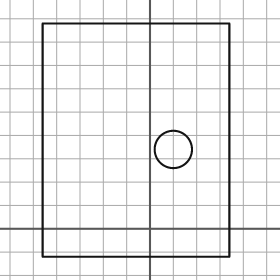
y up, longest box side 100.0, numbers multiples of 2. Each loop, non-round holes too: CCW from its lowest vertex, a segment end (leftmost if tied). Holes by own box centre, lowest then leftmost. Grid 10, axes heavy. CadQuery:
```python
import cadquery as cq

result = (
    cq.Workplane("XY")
    .moveTo(-46.0, -12.0)
    .lineTo(34.0, -12.0)
    .lineTo(34.0, 88.0)
    .lineTo(-46.0, 88.0)
    .close()
    .moveTo(10.0, 34.0)
    .circle(8.0)
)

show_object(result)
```